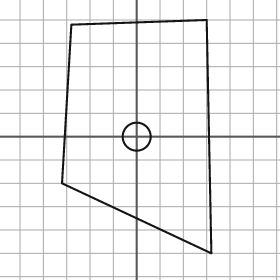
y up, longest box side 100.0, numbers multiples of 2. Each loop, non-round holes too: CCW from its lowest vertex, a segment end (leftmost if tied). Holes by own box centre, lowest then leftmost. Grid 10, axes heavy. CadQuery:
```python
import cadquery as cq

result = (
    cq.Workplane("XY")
    .moveTo(32.0, -50.0)
    .lineTo(30.0, 50.0)
    .lineTo(-28.0, 48.0)
    .lineTo(-32.0, -20.0)
    .close()
    .moveTo(0.0, 0.0)
    .circle(6.0)
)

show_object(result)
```